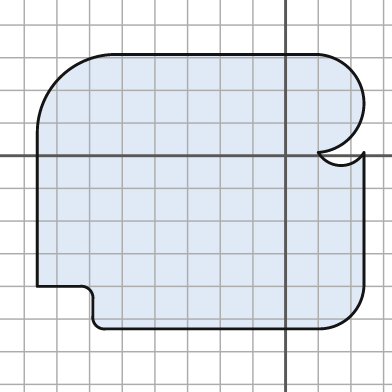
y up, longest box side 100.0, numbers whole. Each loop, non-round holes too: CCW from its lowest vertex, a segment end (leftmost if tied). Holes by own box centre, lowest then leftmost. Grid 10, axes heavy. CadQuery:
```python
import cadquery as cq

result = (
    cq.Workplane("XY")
    .moveTo(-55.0, -53.0)
    .lineTo(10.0, -53.0)
    .threePointArc((20.0, -49.0), (24.0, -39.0))
    .lineTo(24.0, 1.0)
    .threePointArc((17.0, -3.0), (10.0, 1.0))
    .threePointArc((24.0, 16.0), (10.0, 31.0))
    .lineTo(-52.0, 31.0)
    .threePointArc((-69.0, 24.0), (-76.0, 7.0))
    .lineTo(-76.0, -40.0)
    .lineTo(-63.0, -40.0)
    .threePointArc((-60.0, -41.0), (-59.0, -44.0))
    .lineTo(-59.0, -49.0)
    .threePointArc((-58.0, -52.0), (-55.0, -53.0))
    .close()
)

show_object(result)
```